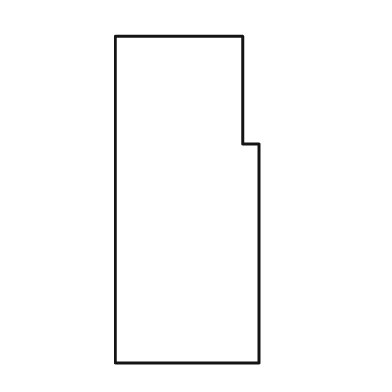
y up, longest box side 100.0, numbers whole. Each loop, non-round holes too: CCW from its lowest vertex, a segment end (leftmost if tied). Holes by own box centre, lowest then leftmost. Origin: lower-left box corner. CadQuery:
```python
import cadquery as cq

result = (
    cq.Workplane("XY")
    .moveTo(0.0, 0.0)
    .lineTo(44.0, 0.0)
    .lineTo(44.0, 67.0)
    .lineTo(39.0, 67.0)
    .lineTo(39.0, 100.0)
    .lineTo(0.0, 100.0)
    .close()
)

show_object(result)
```